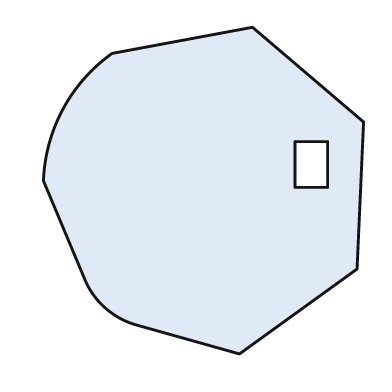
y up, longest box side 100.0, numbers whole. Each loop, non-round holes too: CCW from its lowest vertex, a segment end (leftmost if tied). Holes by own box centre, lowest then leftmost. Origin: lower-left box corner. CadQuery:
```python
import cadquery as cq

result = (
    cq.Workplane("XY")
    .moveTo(60.0, 0.0)
    .lineTo(96.0, 26.0)
    .lineTo(98.0, 71.0)
    .lineTo(64.0, 100.0)
    .lineTo(21.0, 92.0)
    .threePointArc((6.0, 75.0), (0.0, 53.0))
    .lineTo(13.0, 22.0)
    .threePointArc((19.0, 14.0), (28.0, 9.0))
    .close()
    .moveTo(77.0, 51.0)
    .lineTo(87.0, 51.0)
    .lineTo(87.0, 65.0)
    .lineTo(77.0, 65.0)
    .close()
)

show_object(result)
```